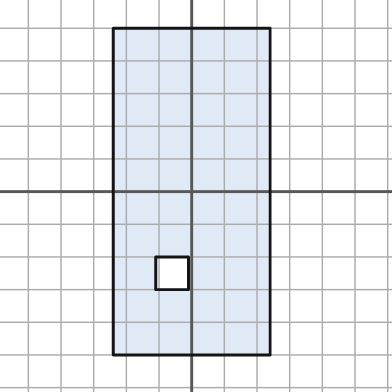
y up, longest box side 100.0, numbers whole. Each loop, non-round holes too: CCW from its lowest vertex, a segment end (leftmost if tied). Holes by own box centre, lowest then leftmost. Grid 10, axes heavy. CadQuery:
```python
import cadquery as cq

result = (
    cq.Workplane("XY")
    .moveTo(-24.0, -50.0)
    .lineTo(24.0, -50.0)
    .lineTo(24.0, 50.0)
    .lineTo(-24.0, 50.0)
    .close()
    .moveTo(-11.0, -30.0)
    .lineTo(-1.0, -30.0)
    .lineTo(-1.0, -20.0)
    .lineTo(-11.0, -20.0)
    .close()
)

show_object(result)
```